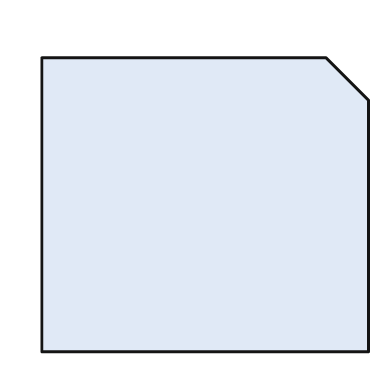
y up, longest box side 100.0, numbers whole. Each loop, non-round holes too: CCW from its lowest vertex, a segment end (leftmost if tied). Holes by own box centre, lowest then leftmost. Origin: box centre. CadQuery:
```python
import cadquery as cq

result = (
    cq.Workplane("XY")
    .moveTo(-50.0, -45.0)
    .lineTo(50.0, -45.0)
    .lineTo(50.0, 32.0)
    .lineTo(37.0, 45.0)
    .lineTo(-50.0, 45.0)
    .close()
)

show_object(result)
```